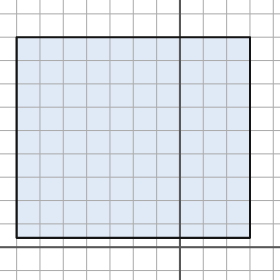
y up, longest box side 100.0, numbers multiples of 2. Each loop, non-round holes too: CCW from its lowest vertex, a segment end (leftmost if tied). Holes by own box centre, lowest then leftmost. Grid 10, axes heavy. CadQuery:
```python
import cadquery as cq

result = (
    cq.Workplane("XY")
    .moveTo(-70.0, 4.0)
    .lineTo(30.0, 4.0)
    .lineTo(30.0, 90.0)
    .lineTo(-70.0, 90.0)
    .close()
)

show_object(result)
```